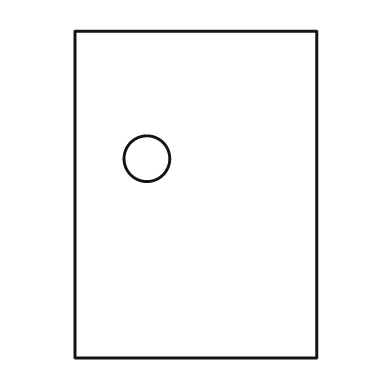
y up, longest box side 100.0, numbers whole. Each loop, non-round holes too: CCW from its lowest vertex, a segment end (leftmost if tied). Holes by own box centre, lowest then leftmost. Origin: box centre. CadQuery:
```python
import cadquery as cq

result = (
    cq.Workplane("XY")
    .moveTo(-37.0, -50.0)
    .lineTo(37.0, -50.0)
    .lineTo(37.0, 50.0)
    .lineTo(-37.0, 50.0)
    .close()
    .moveTo(-15.0, 11.0)
    .circle(7.0)
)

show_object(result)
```